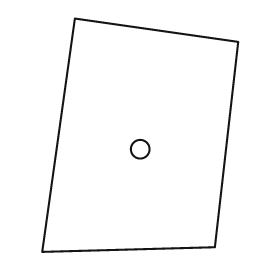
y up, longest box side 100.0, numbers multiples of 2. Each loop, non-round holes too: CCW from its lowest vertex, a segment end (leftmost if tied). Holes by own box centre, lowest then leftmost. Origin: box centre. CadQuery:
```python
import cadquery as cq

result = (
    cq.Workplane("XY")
    .moveTo(-42.0, -50.0)
    .lineTo(32.0, -48.0)
    .lineTo(42.0, 40.0)
    .lineTo(-28.0, 50.0)
    .close()
    .moveTo(0.0, -6.0)
    .circle(4.0)
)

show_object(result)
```